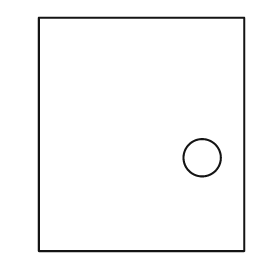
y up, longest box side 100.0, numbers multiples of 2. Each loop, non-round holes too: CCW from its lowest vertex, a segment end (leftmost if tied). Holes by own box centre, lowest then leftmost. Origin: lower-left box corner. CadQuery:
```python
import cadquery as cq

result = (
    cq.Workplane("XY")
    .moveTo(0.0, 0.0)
    .lineTo(88.0, 0.0)
    .lineTo(88.0, 100.0)
    .lineTo(0.0, 100.0)
    .close()
    .moveTo(70.0, 40.0)
    .circle(8.0)
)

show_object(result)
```